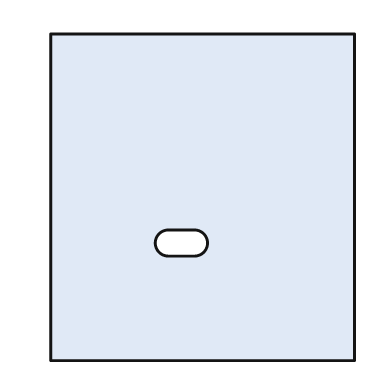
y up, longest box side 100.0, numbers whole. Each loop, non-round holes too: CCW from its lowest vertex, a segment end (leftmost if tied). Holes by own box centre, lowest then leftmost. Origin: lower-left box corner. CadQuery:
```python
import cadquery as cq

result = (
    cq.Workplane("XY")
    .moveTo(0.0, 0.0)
    .lineTo(93.0, 0.0)
    .lineTo(93.0, 100.0)
    .lineTo(0.0, 100.0)
    .close()
    .moveTo(36.0, 32.0)
    .lineTo(44.0, 32.0)
    .threePointArc((48.0, 36.0), (44.0, 40.0))
    .lineTo(36.0, 40.0)
    .threePointArc((32.0, 36.0), (36.0, 32.0))
    .close()
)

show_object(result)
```